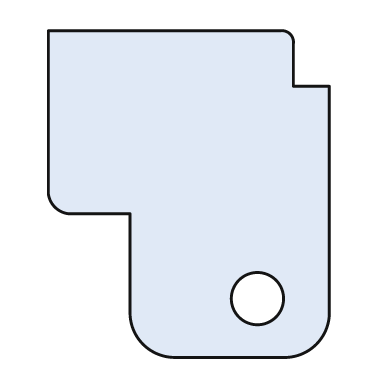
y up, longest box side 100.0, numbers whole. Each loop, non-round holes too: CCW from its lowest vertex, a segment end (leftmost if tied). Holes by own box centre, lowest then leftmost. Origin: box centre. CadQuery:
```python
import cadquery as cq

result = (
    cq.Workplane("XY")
    .moveTo(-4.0, -50.0)
    .lineTo(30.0, -50.0)
    .threePointArc((39.0, -46.0), (43.0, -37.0))
    .lineTo(43.0, 33.0)
    .lineTo(32.0, 33.0)
    .lineTo(32.0, 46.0)
    .threePointArc((31.0, 49.0), (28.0, 50.0))
    .lineTo(-43.0, 50.0)
    .lineTo(-43.0, 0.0)
    .threePointArc((-41.0, -4.0), (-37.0, -6.0))
    .lineTo(-18.0, -6.0)
    .lineTo(-18.0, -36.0)
    .threePointArc((-14.0, -46.0), (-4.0, -50.0))
    .close()
    .moveTo(21.0, -32.0)
    .circle(8.0)
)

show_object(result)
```